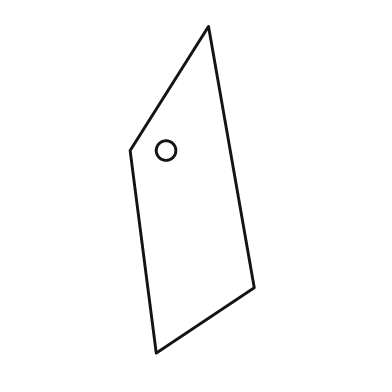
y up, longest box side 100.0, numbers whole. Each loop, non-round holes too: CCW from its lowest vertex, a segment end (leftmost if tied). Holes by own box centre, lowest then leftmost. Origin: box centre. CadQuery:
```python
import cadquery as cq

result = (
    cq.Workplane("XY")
    .moveTo(-11.0, -50.0)
    .lineTo(19.0, -30.0)
    .lineTo(5.0, 50.0)
    .lineTo(-19.0, 12.0)
    .close()
    .moveTo(-8.0, 12.0)
    .circle(3.0)
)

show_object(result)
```